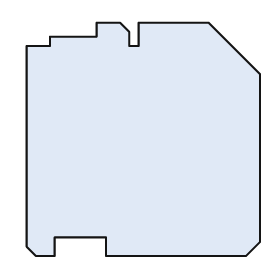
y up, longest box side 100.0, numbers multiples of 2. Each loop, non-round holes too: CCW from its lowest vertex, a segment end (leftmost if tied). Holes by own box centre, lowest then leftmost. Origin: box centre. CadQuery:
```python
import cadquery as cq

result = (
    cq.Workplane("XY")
    .moveTo(-46.0, -50.0)
    .lineTo(-38.0, -50.0)
    .lineTo(-38.0, -42.0)
    .lineTo(-16.0, -42.0)
    .lineTo(-16.0, -50.0)
    .lineTo(44.0, -50.0)
    .lineTo(50.0, -44.0)
    .lineTo(50.0, 28.0)
    .lineTo(28.0, 50.0)
    .lineTo(-2.0, 50.0)
    .lineTo(-2.0, 40.0)
    .lineTo(-6.0, 40.0)
    .lineTo(-6.0, 46.0)
    .lineTo(-10.0, 50.0)
    .lineTo(-20.0, 50.0)
    .lineTo(-20.0, 44.0)
    .lineTo(-40.0, 44.0)
    .lineTo(-40.0, 40.0)
    .lineTo(-50.0, 40.0)
    .lineTo(-50.0, -46.0)
    .close()
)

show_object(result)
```